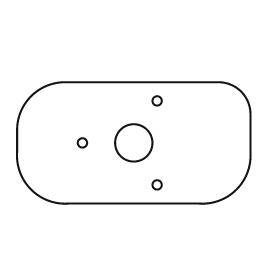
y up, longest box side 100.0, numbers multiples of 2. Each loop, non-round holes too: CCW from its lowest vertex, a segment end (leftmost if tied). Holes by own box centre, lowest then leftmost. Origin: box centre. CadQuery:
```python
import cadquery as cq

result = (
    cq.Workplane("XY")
    .moveTo(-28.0, -26.0)
    .lineTo(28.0, -26.0)
    .threePointArc((44.0, -20.0), (50.0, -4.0))
    .lineTo(50.0, 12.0)
    .threePointArc((46.0, 22.0), (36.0, 26.0))
    .lineTo(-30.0, 26.0)
    .threePointArc((-44.0, 20.0), (-50.0, 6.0))
    .lineTo(-50.0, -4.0)
    .threePointArc((-44.0, -20.0), (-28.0, -26.0))
    .close()
    .moveTo(10.0, -18.0)
    .circle(2.0)
    .moveTo(-22.0, 0.0)
    .circle(2.0)
    .moveTo(0.0, 0.0)
    .circle(8.0)
    .moveTo(10.0, 18.0)
    .circle(2.0)
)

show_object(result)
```